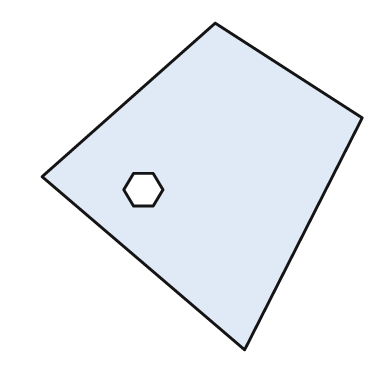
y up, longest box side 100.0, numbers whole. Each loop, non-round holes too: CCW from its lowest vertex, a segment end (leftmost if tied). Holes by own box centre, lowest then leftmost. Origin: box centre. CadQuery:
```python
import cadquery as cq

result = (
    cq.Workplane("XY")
    .moveTo(13.0, -50.0)
    .lineTo(49.0, 21.0)
    .lineTo(4.0, 50.0)
    .lineTo(-49.0, 3.0)
    .close()
    .moveTo(-21.0, -6.0)
    .lineTo(-15.0, -6.0)
    .lineTo(-12.0, -1.0)
    .lineTo(-15.0, 4.0)
    .lineTo(-21.0, 4.0)
    .lineTo(-24.0, -1.0)
    .close()
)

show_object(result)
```